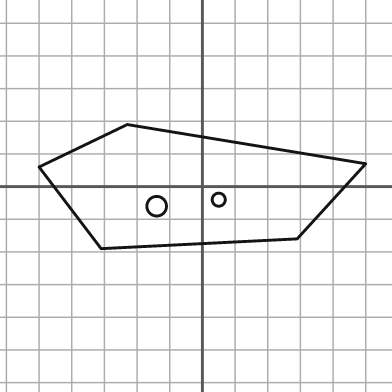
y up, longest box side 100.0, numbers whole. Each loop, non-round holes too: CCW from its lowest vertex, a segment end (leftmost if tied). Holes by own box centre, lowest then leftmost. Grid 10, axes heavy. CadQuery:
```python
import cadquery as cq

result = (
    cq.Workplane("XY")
    .moveTo(-31.0, -19.0)
    .lineTo(29.0, -16.0)
    .lineTo(50.0, 7.0)
    .lineTo(-23.0, 19.0)
    .lineTo(-50.0, 6.0)
    .close()
    .moveTo(-14.0, -6.0)
    .circle(3.0)
    .moveTo(5.0, -4.0)
    .circle(2.0)
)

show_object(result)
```